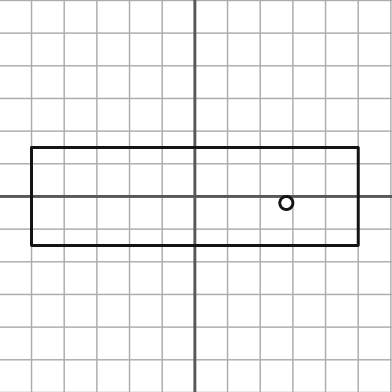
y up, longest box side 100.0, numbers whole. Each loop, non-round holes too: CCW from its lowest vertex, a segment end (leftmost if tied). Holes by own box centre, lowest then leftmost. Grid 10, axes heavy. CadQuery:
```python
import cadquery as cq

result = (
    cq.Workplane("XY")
    .moveTo(-50.0, -15.0)
    .lineTo(50.0, -15.0)
    .lineTo(50.0, 15.0)
    .lineTo(-50.0, 15.0)
    .close()
    .moveTo(28.0, -2.0)
    .circle(2.0)
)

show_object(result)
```